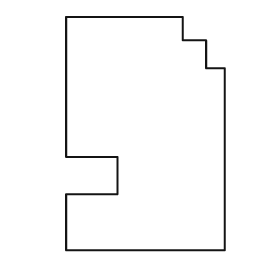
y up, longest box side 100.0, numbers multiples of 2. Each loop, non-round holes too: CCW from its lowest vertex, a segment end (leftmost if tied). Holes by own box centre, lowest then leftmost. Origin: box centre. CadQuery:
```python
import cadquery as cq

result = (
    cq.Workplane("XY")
    .moveTo(-34.0, -50.0)
    .lineTo(34.0, -50.0)
    .lineTo(34.0, 28.0)
    .lineTo(26.0, 28.0)
    .lineTo(26.0, 40.0)
    .lineTo(16.0, 40.0)
    .lineTo(16.0, 50.0)
    .lineTo(-34.0, 50.0)
    .lineTo(-34.0, -10.0)
    .lineTo(-12.0, -10.0)
    .lineTo(-12.0, -26.0)
    .lineTo(-34.0, -26.0)
    .close()
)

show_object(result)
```